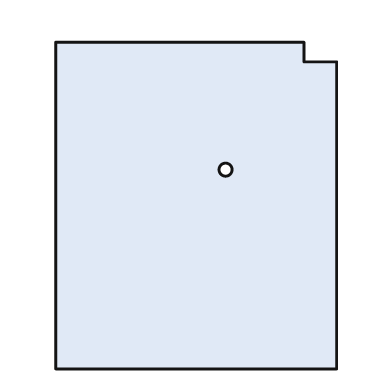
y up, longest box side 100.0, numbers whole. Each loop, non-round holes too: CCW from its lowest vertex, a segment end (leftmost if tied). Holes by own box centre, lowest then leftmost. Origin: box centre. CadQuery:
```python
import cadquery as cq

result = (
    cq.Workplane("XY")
    .moveTo(-43.0, -50.0)
    .lineTo(43.0, -50.0)
    .lineTo(43.0, 44.0)
    .lineTo(33.0, 44.0)
    .lineTo(33.0, 50.0)
    .lineTo(-43.0, 50.0)
    .close()
    .moveTo(9.0, 11.0)
    .circle(2.0)
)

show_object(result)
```